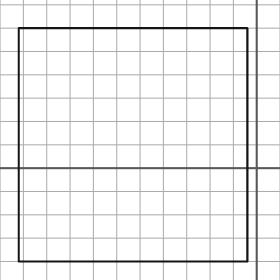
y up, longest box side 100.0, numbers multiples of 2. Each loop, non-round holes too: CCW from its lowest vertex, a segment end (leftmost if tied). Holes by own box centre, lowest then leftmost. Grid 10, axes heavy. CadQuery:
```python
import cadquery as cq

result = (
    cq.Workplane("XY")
    .moveTo(-102.0, -40.0)
    .lineTo(-4.0, -40.0)
    .lineTo(-4.0, 60.0)
    .lineTo(-102.0, 60.0)
    .close()
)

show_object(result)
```